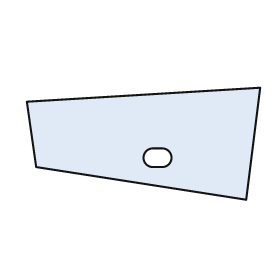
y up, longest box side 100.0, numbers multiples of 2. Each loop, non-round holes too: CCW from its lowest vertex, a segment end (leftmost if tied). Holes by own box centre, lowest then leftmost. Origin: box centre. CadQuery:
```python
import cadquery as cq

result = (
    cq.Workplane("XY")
    .moveTo(44.0, -24.0)
    .lineTo(50.0, 24.0)
    .lineTo(-50.0, 18.0)
    .lineTo(-46.0, -10.0)
    .close()
    .moveTo(4.0, -10.0)
    .lineTo(8.0, -10.0)
    .threePointArc((12.0, -6.0), (8.0, -2.0))
    .lineTo(4.0, -2.0)
    .threePointArc((0.0, -6.0), (4.0, -10.0))
    .close()
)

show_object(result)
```